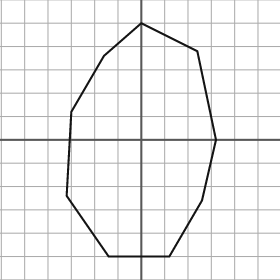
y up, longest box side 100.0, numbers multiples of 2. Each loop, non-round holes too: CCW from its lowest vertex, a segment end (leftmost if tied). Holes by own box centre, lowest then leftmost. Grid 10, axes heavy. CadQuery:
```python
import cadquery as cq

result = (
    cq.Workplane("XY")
    .moveTo(-14.0, -50.0)
    .lineTo(12.0, -50.0)
    .lineTo(26.0, -26.0)
    .lineTo(32.0, 0.0)
    .lineTo(24.0, 38.0)
    .lineTo(0.0, 50.0)
    .lineTo(-16.0, 36.0)
    .lineTo(-30.0, 12.0)
    .lineTo(-32.0, -24.0)
    .close()
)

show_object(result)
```